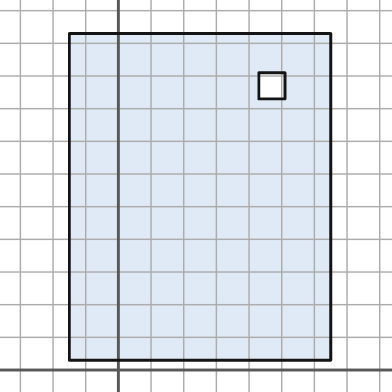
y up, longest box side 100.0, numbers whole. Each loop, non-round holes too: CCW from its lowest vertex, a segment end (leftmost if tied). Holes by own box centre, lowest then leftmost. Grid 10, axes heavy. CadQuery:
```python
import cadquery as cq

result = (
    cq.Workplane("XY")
    .moveTo(-15.0, 3.0)
    .lineTo(65.0, 3.0)
    .lineTo(65.0, 103.0)
    .lineTo(-15.0, 103.0)
    .close()
    .moveTo(43.0, 83.0)
    .lineTo(51.0, 83.0)
    .lineTo(51.0, 91.0)
    .lineTo(43.0, 91.0)
    .close()
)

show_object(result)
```